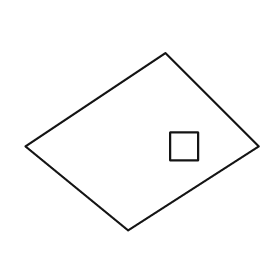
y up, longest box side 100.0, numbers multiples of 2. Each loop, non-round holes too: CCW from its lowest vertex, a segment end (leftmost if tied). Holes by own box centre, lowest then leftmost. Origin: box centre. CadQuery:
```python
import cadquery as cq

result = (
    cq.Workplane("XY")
    .moveTo(-6.0, -38.0)
    .lineTo(50.0, -2.0)
    .lineTo(10.0, 38.0)
    .lineTo(-50.0, -2.0)
    .close()
    .moveTo(12.0, -8.0)
    .lineTo(24.0, -8.0)
    .lineTo(24.0, 4.0)
    .lineTo(12.0, 4.0)
    .close()
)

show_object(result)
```